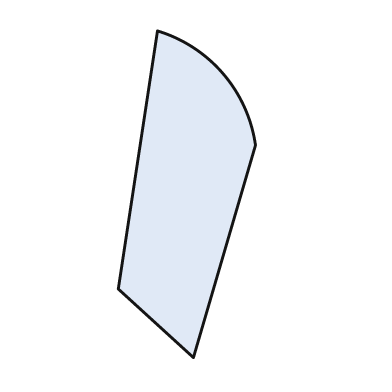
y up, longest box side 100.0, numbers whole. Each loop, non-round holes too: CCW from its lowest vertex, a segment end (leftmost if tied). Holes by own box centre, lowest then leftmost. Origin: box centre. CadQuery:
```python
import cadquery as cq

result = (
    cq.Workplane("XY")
    .moveTo(2.0, -50.0)
    .lineTo(21.0, 15.0)
    .threePointArc((11.0, 37.0), (-9.0, 50.0))
    .lineTo(-21.0, -29.0)
    .close()
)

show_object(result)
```